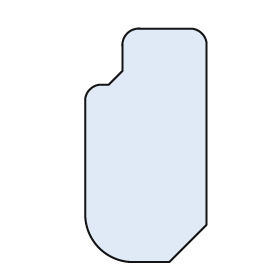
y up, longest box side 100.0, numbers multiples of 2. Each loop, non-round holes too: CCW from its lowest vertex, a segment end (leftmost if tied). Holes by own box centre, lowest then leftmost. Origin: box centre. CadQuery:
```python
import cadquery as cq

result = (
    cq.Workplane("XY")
    .moveTo(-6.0, -50.0)
    .lineTo(10.0, -50.0)
    .lineTo(26.0, -34.0)
    .lineTo(26.0, 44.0)
    .threePointArc((24.0, 48.0), (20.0, 50.0))
    .lineTo(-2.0, 50.0)
    .threePointArc((-8.0, 48.0), (-10.0, 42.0))
    .lineTo(-10.0, 32.0)
    .lineTo(-16.0, 26.0)
    .lineTo(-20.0, 26.0)
    .threePointArc((-24.0, 24.0), (-26.0, 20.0))
    .lineTo(-26.0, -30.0)
    .threePointArc((-20.0, -44.0), (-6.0, -50.0))
    .close()
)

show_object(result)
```